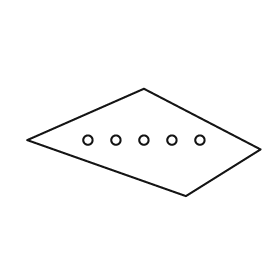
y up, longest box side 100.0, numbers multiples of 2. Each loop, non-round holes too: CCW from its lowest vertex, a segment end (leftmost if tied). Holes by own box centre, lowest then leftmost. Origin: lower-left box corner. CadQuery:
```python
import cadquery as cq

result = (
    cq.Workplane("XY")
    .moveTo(68.0, 0.0)
    .lineTo(100.0, 20.0)
    .lineTo(50.0, 46.0)
    .lineTo(0.0, 24.0)
    .close()
    .moveTo(26.0, 24.0)
    .circle(2.0)
    .moveTo(38.0, 24.0)
    .circle(2.0)
    .moveTo(50.0, 24.0)
    .circle(2.0)
    .moveTo(62.0, 24.0)
    .circle(2.0)
    .moveTo(74.0, 24.0)
    .circle(2.0)
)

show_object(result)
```